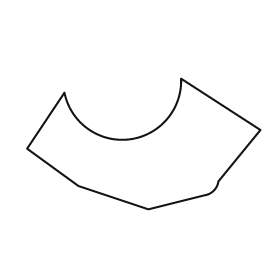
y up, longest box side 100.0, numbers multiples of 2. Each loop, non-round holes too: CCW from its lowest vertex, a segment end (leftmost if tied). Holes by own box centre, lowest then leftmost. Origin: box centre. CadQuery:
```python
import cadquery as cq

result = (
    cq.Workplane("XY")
    .moveTo(2.0, -28.0)
    .lineTo(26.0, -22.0)
    .threePointArc((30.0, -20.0), (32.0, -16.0))
    .lineTo(50.0, 6.0)
    .lineTo(16.0, 28.0)
    .threePointArc((-6.0, 2.0), (-34.0, 22.0))
    .lineTo(-50.0, -2.0)
    .lineTo(-28.0, -18.0)
    .close()
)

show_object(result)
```